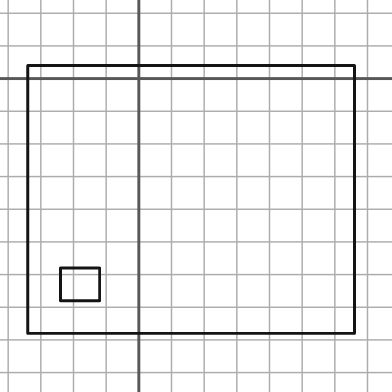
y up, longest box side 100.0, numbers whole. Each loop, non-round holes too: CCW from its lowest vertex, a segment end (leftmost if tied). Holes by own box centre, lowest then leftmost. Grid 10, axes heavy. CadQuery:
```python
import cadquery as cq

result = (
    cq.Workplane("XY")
    .moveTo(-34.0, -78.0)
    .lineTo(66.0, -78.0)
    .lineTo(66.0, 4.0)
    .lineTo(-34.0, 4.0)
    .close()
    .moveTo(-24.0, -68.0)
    .lineTo(-12.0, -68.0)
    .lineTo(-12.0, -58.0)
    .lineTo(-24.0, -58.0)
    .close()
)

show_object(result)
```